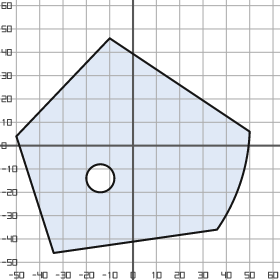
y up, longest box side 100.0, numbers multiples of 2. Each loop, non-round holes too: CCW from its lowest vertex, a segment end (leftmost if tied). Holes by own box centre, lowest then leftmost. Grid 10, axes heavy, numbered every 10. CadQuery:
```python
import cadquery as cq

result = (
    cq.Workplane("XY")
    .moveTo(-34.0, -46.0)
    .lineTo(36.0, -36.0)
    .threePointArc((46.0, -16.0), (50.0, 6.0))
    .lineTo(-10.0, 46.0)
    .lineTo(-50.0, 4.0)
    .close()
    .moveTo(-14.0, -14.0)
    .circle(6.0)
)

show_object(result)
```